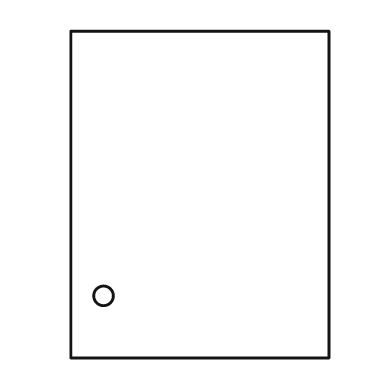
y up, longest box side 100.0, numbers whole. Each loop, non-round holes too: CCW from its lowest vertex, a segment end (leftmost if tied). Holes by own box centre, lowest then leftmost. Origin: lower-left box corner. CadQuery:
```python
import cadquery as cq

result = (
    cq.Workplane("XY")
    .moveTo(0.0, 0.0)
    .lineTo(79.0, 0.0)
    .lineTo(79.0, 100.0)
    .lineTo(0.0, 100.0)
    .close()
    .moveTo(10.0, 19.0)
    .circle(3.0)
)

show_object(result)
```